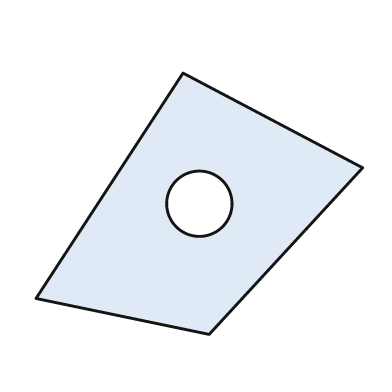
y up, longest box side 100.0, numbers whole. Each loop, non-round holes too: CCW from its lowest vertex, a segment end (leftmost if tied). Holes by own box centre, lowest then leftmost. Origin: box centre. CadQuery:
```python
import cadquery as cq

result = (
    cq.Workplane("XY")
    .moveTo(3.0, -40.0)
    .lineTo(50.0, 11.0)
    .lineTo(-5.0, 40.0)
    .lineTo(-50.0, -29.0)
    .close()
    .moveTo(0.0, 0.0)
    .circle(10.0)
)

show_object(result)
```